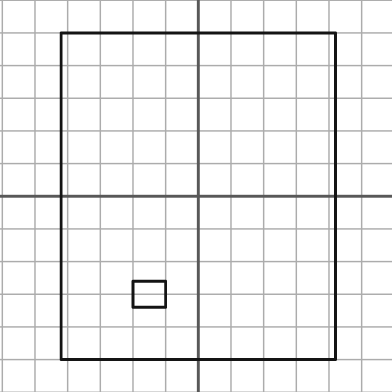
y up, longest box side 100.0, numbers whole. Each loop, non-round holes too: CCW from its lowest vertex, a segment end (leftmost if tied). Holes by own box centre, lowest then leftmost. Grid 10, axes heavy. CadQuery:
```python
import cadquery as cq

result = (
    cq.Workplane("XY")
    .moveTo(-42.0, -50.0)
    .lineTo(42.0, -50.0)
    .lineTo(42.0, 50.0)
    .lineTo(-42.0, 50.0)
    .close()
    .moveTo(-20.0, -34.0)
    .lineTo(-10.0, -34.0)
    .lineTo(-10.0, -26.0)
    .lineTo(-20.0, -26.0)
    .close()
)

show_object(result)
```